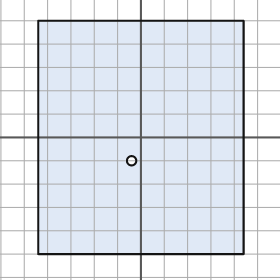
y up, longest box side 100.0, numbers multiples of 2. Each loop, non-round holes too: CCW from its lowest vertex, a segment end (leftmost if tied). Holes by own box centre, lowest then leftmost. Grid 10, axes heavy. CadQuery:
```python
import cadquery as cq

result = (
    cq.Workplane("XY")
    .moveTo(-44.0, -50.0)
    .lineTo(44.0, -50.0)
    .lineTo(44.0, 50.0)
    .lineTo(-44.0, 50.0)
    .close()
    .moveTo(-4.0, -10.0)
    .circle(2.0)
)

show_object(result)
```